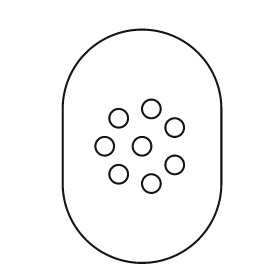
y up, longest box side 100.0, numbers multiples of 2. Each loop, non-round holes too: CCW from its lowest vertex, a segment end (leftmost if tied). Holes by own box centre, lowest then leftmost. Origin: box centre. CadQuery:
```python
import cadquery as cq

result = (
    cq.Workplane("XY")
    .moveTo(-34.0, -16.0)
    .threePointArc((0.0, -50.0), (34.0, -16.0))
    .lineTo(34.0, 16.0)
    .threePointArc((0.0, 50.0), (-34.0, 16.0))
    .close()
    .moveTo(4.0, -16.0)
    .circle(4.0)
    .moveTo(-10.0, -12.0)
    .circle(4.0)
    .moveTo(14.0, -8.0)
    .circle(4.0)
    .moveTo(-16.0, 0.0)
    .circle(4.0)
    .moveTo(0.0, 0.0)
    .circle(4.0)
    .moveTo(14.0, 8.0)
    .circle(4.0)
    .moveTo(-10.0, 12.0)
    .circle(4.0)
    .moveTo(4.0, 16.0)
    .circle(4.0)
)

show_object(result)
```